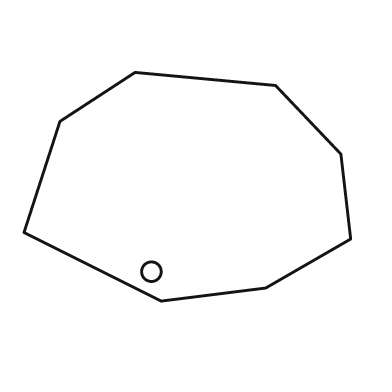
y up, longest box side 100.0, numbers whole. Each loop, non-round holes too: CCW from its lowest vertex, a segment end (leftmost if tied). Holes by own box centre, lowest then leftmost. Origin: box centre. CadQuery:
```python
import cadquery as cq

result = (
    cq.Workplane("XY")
    .moveTo(-8.0, -35.0)
    .lineTo(24.0, -31.0)
    .lineTo(50.0, -16.0)
    .lineTo(47.0, 10.0)
    .lineTo(27.0, 31.0)
    .lineTo(-16.0, 35.0)
    .lineTo(-39.0, 20.0)
    .lineTo(-50.0, -14.0)
    .close()
    .moveTo(-11.0, -26.0)
    .circle(3.0)
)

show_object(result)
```